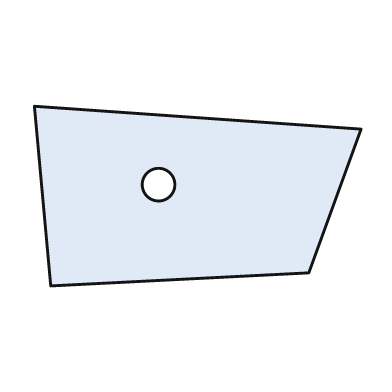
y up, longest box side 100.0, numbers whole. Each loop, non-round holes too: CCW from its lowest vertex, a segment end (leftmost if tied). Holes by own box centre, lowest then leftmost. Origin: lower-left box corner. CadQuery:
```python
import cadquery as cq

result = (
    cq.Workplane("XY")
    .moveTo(5.0, 0.0)
    .lineTo(84.0, 4.0)
    .lineTo(100.0, 48.0)
    .lineTo(0.0, 55.0)
    .close()
    .moveTo(38.0, 31.0)
    .circle(5.0)
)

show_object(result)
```